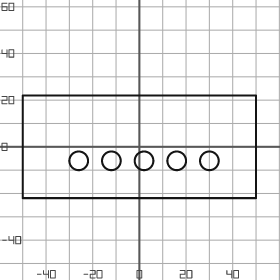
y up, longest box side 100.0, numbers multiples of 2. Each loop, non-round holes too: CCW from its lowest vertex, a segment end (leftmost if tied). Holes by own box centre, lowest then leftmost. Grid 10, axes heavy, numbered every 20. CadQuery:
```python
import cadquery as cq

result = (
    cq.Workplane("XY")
    .moveTo(-50.0, -22.0)
    .lineTo(50.0, -22.0)
    .lineTo(50.0, 22.0)
    .lineTo(-50.0, 22.0)
    .close()
    .moveTo(-26.0, -6.0)
    .circle(4.0)
    .moveTo(-12.0, -6.0)
    .circle(4.0)
    .moveTo(2.0, -6.0)
    .circle(4.0)
    .moveTo(16.0, -6.0)
    .circle(4.0)
    .moveTo(30.0, -6.0)
    .circle(4.0)
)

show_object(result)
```